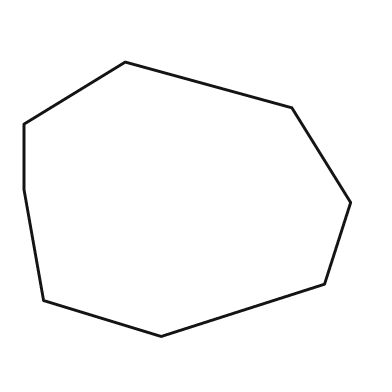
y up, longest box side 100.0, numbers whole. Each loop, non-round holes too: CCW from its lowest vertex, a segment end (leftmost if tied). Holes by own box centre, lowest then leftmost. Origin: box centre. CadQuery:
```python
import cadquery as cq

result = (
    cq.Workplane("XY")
    .moveTo(-8.0, -42.0)
    .lineTo(42.0, -26.0)
    .lineTo(50.0, -1.0)
    .lineTo(32.0, 28.0)
    .lineTo(-19.0, 42.0)
    .lineTo(-50.0, 23.0)
    .lineTo(-50.0, 3.0)
    .lineTo(-44.0, -31.0)
    .close()
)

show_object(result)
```